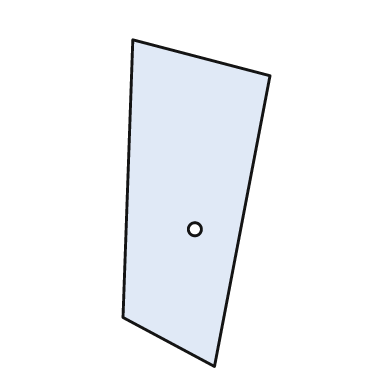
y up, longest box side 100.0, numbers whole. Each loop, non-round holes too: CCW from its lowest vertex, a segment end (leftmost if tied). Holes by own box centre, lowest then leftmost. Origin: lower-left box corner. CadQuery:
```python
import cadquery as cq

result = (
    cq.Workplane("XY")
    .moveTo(28.0, 0.0)
    .lineTo(45.0, 89.0)
    .lineTo(3.0, 100.0)
    .lineTo(0.0, 15.0)
    .close()
    .moveTo(22.0, 42.0)
    .circle(2.0)
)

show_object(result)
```